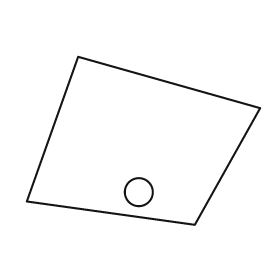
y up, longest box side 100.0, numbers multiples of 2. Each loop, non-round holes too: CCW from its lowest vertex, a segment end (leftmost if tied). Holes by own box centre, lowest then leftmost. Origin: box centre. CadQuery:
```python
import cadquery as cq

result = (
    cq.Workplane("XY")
    .moveTo(22.0, -36.0)
    .lineTo(50.0, 14.0)
    .lineTo(-28.0, 36.0)
    .lineTo(-50.0, -26.0)
    .close()
    .moveTo(-2.0, -22.0)
    .circle(6.0)
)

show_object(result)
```